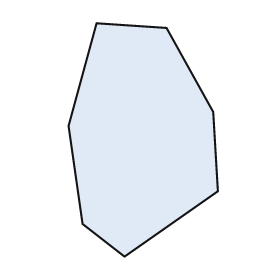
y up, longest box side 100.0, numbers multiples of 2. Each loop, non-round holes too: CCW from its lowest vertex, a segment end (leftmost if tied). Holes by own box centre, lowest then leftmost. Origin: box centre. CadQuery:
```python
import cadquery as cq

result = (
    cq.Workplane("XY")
    .moveTo(-8.0, -50.0)
    .lineTo(32.0, -22.0)
    .lineTo(30.0, 12.0)
    .lineTo(10.0, 48.0)
    .lineTo(-20.0, 50.0)
    .lineTo(-32.0, 6.0)
    .lineTo(-26.0, -36.0)
    .close()
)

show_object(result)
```